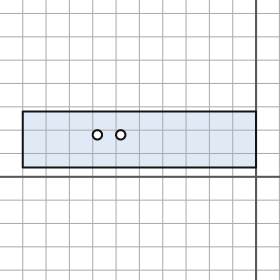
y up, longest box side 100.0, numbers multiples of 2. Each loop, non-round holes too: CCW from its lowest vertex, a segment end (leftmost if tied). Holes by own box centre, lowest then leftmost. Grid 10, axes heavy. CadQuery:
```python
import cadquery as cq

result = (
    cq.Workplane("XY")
    .moveTo(-100.0, 4.0)
    .lineTo(0.0, 4.0)
    .lineTo(0.0, 28.0)
    .lineTo(-100.0, 28.0)
    .close()
    .moveTo(-68.0, 18.0)
    .circle(2.0)
    .moveTo(-58.0, 18.0)
    .circle(2.0)
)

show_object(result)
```